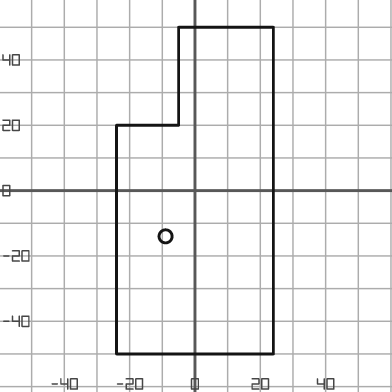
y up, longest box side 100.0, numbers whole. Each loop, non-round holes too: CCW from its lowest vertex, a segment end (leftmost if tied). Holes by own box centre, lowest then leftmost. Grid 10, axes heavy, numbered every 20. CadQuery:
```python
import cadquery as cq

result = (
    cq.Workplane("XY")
    .moveTo(-24.0, -50.0)
    .lineTo(24.0, -50.0)
    .lineTo(24.0, 50.0)
    .lineTo(-5.0, 50.0)
    .lineTo(-5.0, 20.0)
    .lineTo(-24.0, 20.0)
    .close()
    .moveTo(-9.0, -14.0)
    .circle(2.0)
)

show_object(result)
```